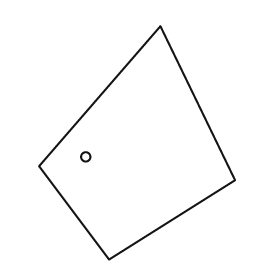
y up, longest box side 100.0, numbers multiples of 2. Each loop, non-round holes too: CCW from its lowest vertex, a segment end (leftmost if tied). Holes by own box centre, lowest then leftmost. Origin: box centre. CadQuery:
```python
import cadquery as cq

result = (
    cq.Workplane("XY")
    .moveTo(-12.0, -50.0)
    .lineTo(42.0, -16.0)
    .lineTo(10.0, 50.0)
    .lineTo(-42.0, -10.0)
    .close()
    .moveTo(-22.0, -6.0)
    .circle(2.0)
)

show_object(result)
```